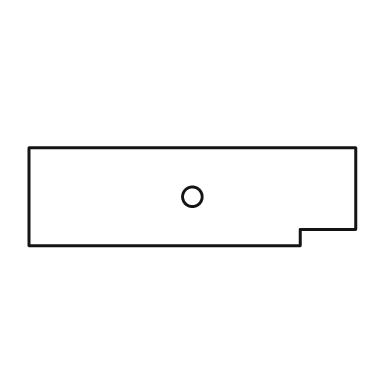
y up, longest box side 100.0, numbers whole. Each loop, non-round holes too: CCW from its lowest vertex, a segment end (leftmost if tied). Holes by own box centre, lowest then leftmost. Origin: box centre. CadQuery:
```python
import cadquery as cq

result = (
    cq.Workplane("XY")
    .moveTo(-50.0, -15.0)
    .lineTo(33.0, -15.0)
    .lineTo(33.0, -10.0)
    .lineTo(50.0, -10.0)
    .lineTo(50.0, 15.0)
    .lineTo(-50.0, 15.0)
    .close()
    .moveTo(0.0, 0.0)
    .circle(3.0)
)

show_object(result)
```